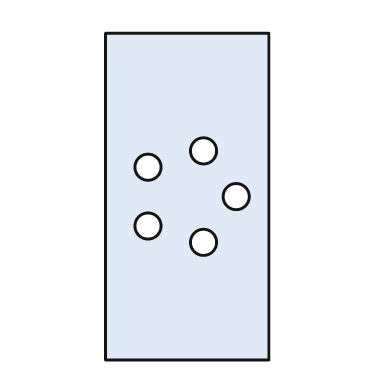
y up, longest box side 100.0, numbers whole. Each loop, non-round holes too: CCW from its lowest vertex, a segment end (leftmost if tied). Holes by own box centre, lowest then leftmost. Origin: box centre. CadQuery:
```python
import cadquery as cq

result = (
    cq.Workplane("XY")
    .moveTo(-25.0, -50.0)
    .lineTo(25.0, -50.0)
    .lineTo(25.0, 50.0)
    .lineTo(-25.0, 50.0)
    .close()
    .moveTo(5.0, -14.0)
    .circle(4.0)
    .moveTo(-12.0, -9.0)
    .circle(4.0)
    .moveTo(15.0, 0.0)
    .circle(4.0)
    .moveTo(-12.0, 9.0)
    .circle(4.0)
    .moveTo(5.0, 14.0)
    .circle(4.0)
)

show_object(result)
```